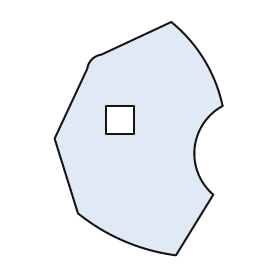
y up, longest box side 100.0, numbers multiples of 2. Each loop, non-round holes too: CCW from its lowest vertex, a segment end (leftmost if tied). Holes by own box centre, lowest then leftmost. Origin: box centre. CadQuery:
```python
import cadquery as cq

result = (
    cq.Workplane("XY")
    .moveTo(16.0, -50.0)
    .lineTo(32.0, -24.0)
    .threePointArc((24.0, -4.0), (36.0, 14.0))
    .threePointArc((28.0, 34.0), (14.0, 50.0))
    .lineTo(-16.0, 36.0)
    .threePointArc((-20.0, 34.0), (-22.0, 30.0))
    .lineTo(-36.0, 0.0)
    .lineTo(-26.0, -32.0)
    .threePointArc((-6.0, -44.0), (16.0, -50.0))
    .close()
    .moveTo(-14.0, 2.0)
    .lineTo(-2.0, 2.0)
    .lineTo(-2.0, 14.0)
    .lineTo(-14.0, 14.0)
    .close()
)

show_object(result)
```